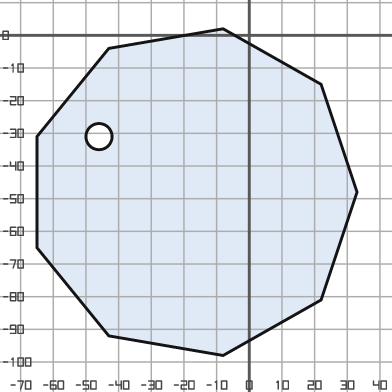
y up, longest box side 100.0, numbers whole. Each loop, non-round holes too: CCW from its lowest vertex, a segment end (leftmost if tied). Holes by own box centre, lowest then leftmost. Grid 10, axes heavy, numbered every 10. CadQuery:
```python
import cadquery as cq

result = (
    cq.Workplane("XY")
    .moveTo(-8.0, -98.0)
    .lineTo(22.0, -81.0)
    .lineTo(33.0, -48.0)
    .lineTo(22.0, -15.0)
    .lineTo(-8.0, 2.0)
    .lineTo(-43.0, -4.0)
    .lineTo(-65.0, -31.0)
    .lineTo(-65.0, -65.0)
    .lineTo(-43.0, -92.0)
    .close()
    .moveTo(-46.0, -31.0)
    .circle(4.0)
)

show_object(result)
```